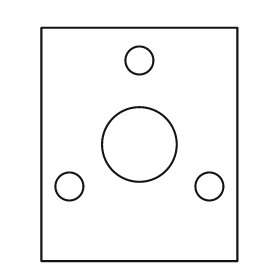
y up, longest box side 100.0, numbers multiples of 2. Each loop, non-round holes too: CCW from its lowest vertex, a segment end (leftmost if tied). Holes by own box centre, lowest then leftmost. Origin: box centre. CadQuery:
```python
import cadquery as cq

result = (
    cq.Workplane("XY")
    .moveTo(-42.0, -50.0)
    .lineTo(42.0, -50.0)
    .lineTo(42.0, 50.0)
    .lineTo(-42.0, 50.0)
    .close()
    .moveTo(-30.0, -18.0)
    .circle(6.0)
    .moveTo(30.0, -18.0)
    .circle(6.0)
    .moveTo(0.0, 0.0)
    .circle(16.0)
    .moveTo(0.0, 36.0)
    .circle(6.0)
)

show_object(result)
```